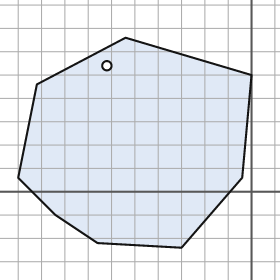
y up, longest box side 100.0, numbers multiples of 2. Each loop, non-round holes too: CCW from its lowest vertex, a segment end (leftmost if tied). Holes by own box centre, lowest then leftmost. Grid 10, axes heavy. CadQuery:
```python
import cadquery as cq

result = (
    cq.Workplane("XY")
    .moveTo(-30.0, -24.0)
    .lineTo(-4.0, 6.0)
    .lineTo(0.0, 50.0)
    .lineTo(-54.0, 66.0)
    .lineTo(-92.0, 46.0)
    .lineTo(-100.0, 6.0)
    .lineTo(-84.0, -10.0)
    .lineTo(-66.0, -22.0)
    .close()
    .moveTo(-62.0, 54.0)
    .circle(2.0)
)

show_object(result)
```